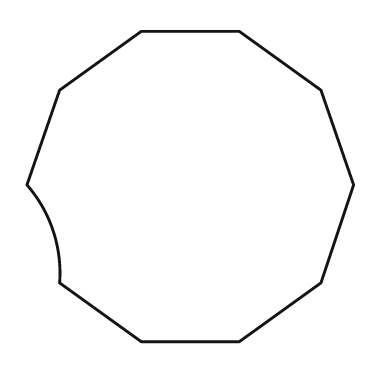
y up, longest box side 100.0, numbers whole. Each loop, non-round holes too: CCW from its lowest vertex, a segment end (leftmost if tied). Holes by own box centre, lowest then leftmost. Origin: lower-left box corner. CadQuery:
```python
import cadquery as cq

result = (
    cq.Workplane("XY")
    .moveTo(35.0, 0.0)
    .lineTo(65.0, 0.0)
    .lineTo(90.0, 18.0)
    .lineTo(100.0, 48.0)
    .lineTo(90.0, 77.0)
    .lineTo(65.0, 95.0)
    .lineTo(35.0, 95.0)
    .lineTo(10.0, 77.0)
    .lineTo(0.0, 48.0)
    .threePointArc((8.0, 34.0), (10.0, 18.0))
    .close()
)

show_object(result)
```